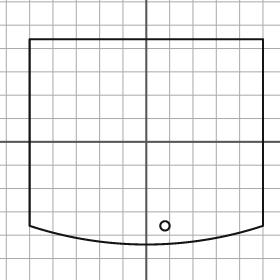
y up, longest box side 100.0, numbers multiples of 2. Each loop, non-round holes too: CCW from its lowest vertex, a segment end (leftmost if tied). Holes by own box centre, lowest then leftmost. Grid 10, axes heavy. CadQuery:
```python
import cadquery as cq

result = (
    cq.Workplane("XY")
    .moveTo(-50.0, -36.0)
    .threePointArc((0.0, -44.0), (50.0, -36.0))
    .lineTo(50.0, 44.0)
    .lineTo(-50.0, 44.0)
    .close()
    .moveTo(8.0, -36.0)
    .circle(2.0)
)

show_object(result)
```